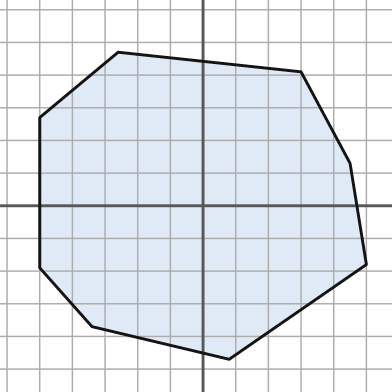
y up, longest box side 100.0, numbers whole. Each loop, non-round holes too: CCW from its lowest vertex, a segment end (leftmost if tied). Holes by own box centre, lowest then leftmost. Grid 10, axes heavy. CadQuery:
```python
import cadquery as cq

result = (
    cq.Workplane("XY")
    .moveTo(8.0, -47.0)
    .lineTo(50.0, -18.0)
    .lineTo(45.0, 13.0)
    .lineTo(30.0, 41.0)
    .lineTo(-26.0, 47.0)
    .lineTo(-50.0, 27.0)
    .lineTo(-50.0, -19.0)
    .lineTo(-34.0, -37.0)
    .close()
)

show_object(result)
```